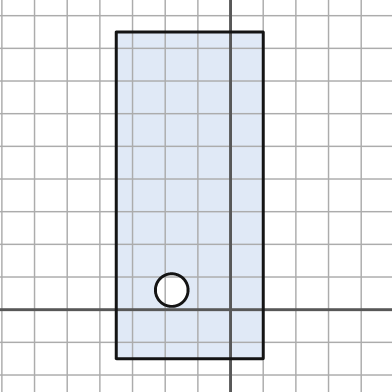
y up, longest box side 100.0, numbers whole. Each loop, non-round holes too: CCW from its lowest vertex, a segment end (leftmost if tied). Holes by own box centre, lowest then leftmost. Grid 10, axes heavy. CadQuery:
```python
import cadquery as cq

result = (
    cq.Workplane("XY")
    .moveTo(-35.0, -15.0)
    .lineTo(10.0, -15.0)
    .lineTo(10.0, 85.0)
    .lineTo(-35.0, 85.0)
    .close()
    .moveTo(-18.0, 6.0)
    .circle(5.0)
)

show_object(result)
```